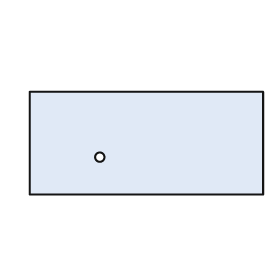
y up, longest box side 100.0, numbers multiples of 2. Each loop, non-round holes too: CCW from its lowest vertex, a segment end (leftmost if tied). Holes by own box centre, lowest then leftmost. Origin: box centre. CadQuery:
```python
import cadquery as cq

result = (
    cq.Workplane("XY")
    .moveTo(-50.0, -22.0)
    .lineTo(50.0, -22.0)
    .lineTo(50.0, 22.0)
    .lineTo(-50.0, 22.0)
    .close()
    .moveTo(-20.0, -6.0)
    .circle(2.0)
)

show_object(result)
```